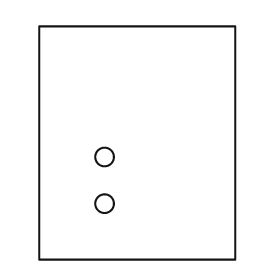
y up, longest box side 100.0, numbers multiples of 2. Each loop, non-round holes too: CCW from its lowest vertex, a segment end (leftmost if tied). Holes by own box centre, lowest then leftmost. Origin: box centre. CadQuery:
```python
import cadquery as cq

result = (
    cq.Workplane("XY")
    .moveTo(-42.0, -50.0)
    .lineTo(42.0, -50.0)
    .lineTo(42.0, 50.0)
    .lineTo(-42.0, 50.0)
    .close()
    .moveTo(-14.0, -26.0)
    .circle(4.0)
    .moveTo(-14.0, -6.0)
    .circle(4.0)
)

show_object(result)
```